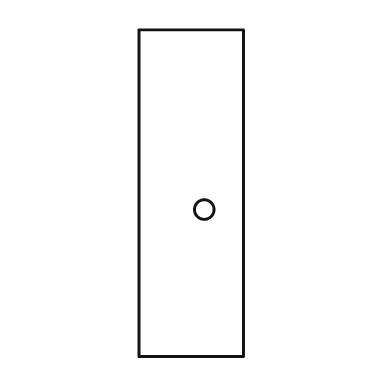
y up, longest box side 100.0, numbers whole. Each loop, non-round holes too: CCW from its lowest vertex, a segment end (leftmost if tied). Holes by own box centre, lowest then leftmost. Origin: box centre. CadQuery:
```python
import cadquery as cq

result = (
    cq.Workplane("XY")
    .moveTo(-16.0, -50.0)
    .lineTo(16.0, -50.0)
    .lineTo(16.0, 50.0)
    .lineTo(-16.0, 50.0)
    .close()
    .moveTo(4.0, -5.0)
    .circle(3.0)
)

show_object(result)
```